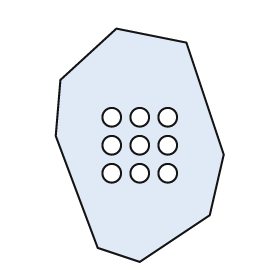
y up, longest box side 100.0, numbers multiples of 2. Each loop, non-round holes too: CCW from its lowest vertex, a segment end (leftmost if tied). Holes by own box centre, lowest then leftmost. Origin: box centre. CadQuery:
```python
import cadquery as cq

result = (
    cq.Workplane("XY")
    .moveTo(0.0, -50.0)
    .lineTo(30.0, -30.0)
    .lineTo(36.0, -4.0)
    .lineTo(20.0, 44.0)
    .lineTo(-10.0, 50.0)
    .lineTo(-34.0, 28.0)
    .lineTo(-36.0, 4.0)
    .lineTo(-18.0, -44.0)
    .close()
    .moveTo(-12.0, -12.0)
    .circle(4.0)
    .moveTo(0.0, -12.0)
    .circle(4.0)
    .moveTo(12.0, -12.0)
    .circle(4.0)
    .moveTo(-12.0, 0.0)
    .circle(4.0)
    .moveTo(0.0, 0.0)
    .circle(4.0)
    .moveTo(12.0, 0.0)
    .circle(4.0)
    .moveTo(-12.0, 12.0)
    .circle(4.0)
    .moveTo(0.0, 12.0)
    .circle(4.0)
    .moveTo(12.0, 12.0)
    .circle(4.0)
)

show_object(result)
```